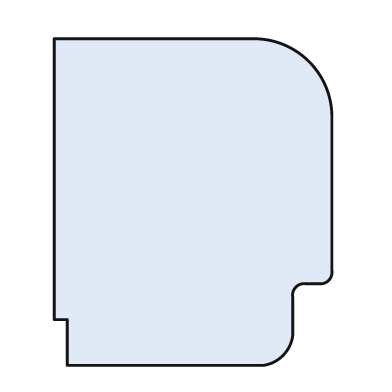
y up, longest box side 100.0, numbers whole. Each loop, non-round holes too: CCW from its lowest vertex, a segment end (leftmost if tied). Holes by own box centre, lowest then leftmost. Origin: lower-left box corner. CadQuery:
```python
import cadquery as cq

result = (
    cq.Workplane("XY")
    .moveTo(4.0, 0.0)
    .lineTo(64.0, 0.0)
    .threePointArc((70.0, 3.0), (73.0, 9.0))
    .lineTo(73.0, 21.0)
    .threePointArc((74.0, 24.0), (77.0, 25.0))
    .lineTo(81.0, 25.0)
    .threePointArc((84.0, 26.0), (85.0, 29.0))
    .lineTo(85.0, 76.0)
    .threePointArc((78.0, 93.0), (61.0, 100.0))
    .lineTo(0.0, 100.0)
    .lineTo(0.0, 14.0)
    .lineTo(4.0, 14.0)
    .close()
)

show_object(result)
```